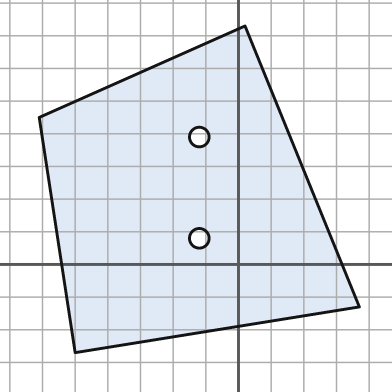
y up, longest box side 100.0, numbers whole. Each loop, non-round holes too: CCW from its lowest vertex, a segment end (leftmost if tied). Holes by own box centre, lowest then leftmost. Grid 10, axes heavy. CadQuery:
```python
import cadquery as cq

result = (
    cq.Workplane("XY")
    .moveTo(-50.0, -27.0)
    .lineTo(37.0, -13.0)
    .lineTo(2.0, 73.0)
    .lineTo(-61.0, 45.0)
    .close()
    .moveTo(-12.0, 8.0)
    .circle(3.0)
    .moveTo(-12.0, 39.0)
    .circle(3.0)
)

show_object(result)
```